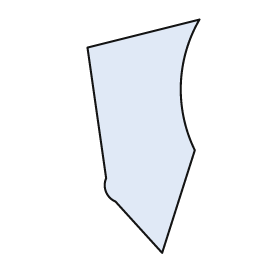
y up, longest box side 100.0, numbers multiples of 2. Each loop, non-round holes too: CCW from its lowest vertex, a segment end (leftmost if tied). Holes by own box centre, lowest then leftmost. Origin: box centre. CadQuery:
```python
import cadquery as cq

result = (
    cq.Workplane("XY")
    .moveTo(8.0, -50.0)
    .lineTo(22.0, -6.0)
    .threePointArc((16.0, 22.0), (24.0, 50.0))
    .lineTo(-24.0, 38.0)
    .lineTo(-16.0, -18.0)
    .threePointArc((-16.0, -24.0), (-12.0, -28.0))
    .close()
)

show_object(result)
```